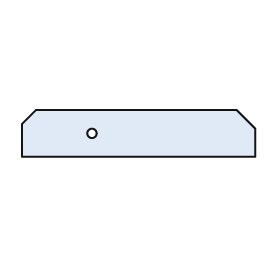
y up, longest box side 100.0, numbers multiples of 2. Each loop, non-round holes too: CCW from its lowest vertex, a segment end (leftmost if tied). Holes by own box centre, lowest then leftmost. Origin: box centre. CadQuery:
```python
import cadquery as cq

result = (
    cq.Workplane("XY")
    .moveTo(-50.0, -10.0)
    .lineTo(50.0, -10.0)
    .lineTo(50.0, 2.0)
    .lineTo(42.0, 10.0)
    .lineTo(-44.0, 10.0)
    .lineTo(-50.0, 4.0)
    .close()
    .moveTo(-20.0, 0.0)
    .circle(2.0)
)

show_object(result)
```